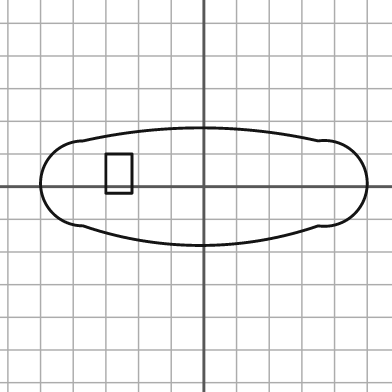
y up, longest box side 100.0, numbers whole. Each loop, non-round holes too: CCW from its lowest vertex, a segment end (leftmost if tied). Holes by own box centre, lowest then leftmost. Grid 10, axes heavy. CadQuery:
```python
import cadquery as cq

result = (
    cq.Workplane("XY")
    .moveTo(-37.0, -12.0)
    .threePointArc((-1.0, -18.0), (35.0, -12.0))
    .threePointArc((50.0, 1.0), (35.0, 14.0))
    .threePointArc((-1.0, 18.0), (-37.0, 14.0))
    .threePointArc((-50.0, 1.0), (-37.0, -12.0))
    .close()
    .moveTo(-30.0, -2.0)
    .lineTo(-22.0, -2.0)
    .lineTo(-22.0, 10.0)
    .lineTo(-30.0, 10.0)
    .close()
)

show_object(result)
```